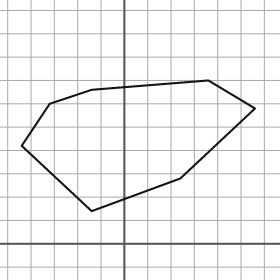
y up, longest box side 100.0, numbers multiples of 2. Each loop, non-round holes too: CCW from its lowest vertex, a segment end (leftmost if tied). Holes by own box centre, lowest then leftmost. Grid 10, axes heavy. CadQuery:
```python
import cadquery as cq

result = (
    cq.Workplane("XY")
    .moveTo(-14.0, 14.0)
    .lineTo(24.0, 28.0)
    .lineTo(56.0, 58.0)
    .lineTo(36.0, 70.0)
    .lineTo(-14.0, 66.0)
    .lineTo(-32.0, 60.0)
    .lineTo(-44.0, 42.0)
    .close()
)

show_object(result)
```